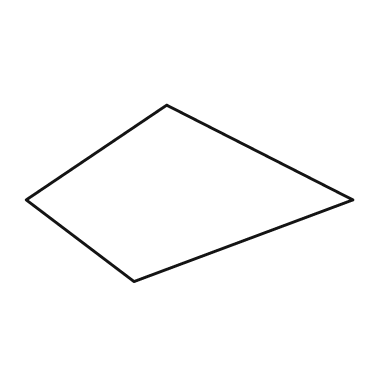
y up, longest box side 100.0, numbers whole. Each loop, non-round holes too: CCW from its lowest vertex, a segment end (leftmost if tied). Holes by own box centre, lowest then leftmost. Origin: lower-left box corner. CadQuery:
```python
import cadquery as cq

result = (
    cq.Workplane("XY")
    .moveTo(33.0, 0.0)
    .lineTo(100.0, 25.0)
    .lineTo(43.0, 54.0)
    .lineTo(0.0, 25.0)
    .close()
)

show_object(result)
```